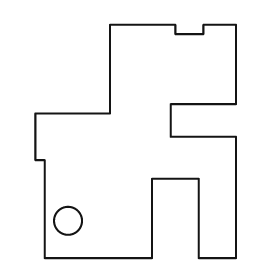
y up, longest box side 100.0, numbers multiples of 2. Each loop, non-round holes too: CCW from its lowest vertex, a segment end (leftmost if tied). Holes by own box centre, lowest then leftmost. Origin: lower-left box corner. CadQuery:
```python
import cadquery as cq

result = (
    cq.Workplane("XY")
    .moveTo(4.0, 0.0)
    .lineTo(50.0, 0.0)
    .lineTo(50.0, 34.0)
    .lineTo(70.0, 34.0)
    .lineTo(70.0, 0.0)
    .lineTo(86.0, 0.0)
    .lineTo(86.0, 52.0)
    .lineTo(58.0, 52.0)
    .lineTo(58.0, 66.0)
    .lineTo(86.0, 66.0)
    .lineTo(86.0, 100.0)
    .lineTo(72.0, 100.0)
    .lineTo(72.0, 96.0)
    .lineTo(60.0, 96.0)
    .lineTo(60.0, 100.0)
    .lineTo(32.0, 100.0)
    .lineTo(32.0, 62.0)
    .lineTo(0.0, 62.0)
    .lineTo(0.0, 42.0)
    .lineTo(4.0, 42.0)
    .close()
    .moveTo(14.0, 16.0)
    .circle(6.0)
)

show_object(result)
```